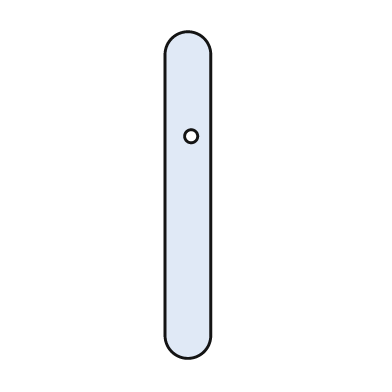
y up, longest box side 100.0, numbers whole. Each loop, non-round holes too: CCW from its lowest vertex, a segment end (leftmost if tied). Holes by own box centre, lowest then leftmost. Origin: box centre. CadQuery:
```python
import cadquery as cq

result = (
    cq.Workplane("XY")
    .moveTo(-7.0, -43.0)
    .threePointArc((0.0, -50.0), (7.0, -43.0))
    .lineTo(7.0, 43.0)
    .threePointArc((0.0, 50.0), (-7.0, 43.0))
    .close()
    .moveTo(1.0, 18.0)
    .circle(2.0)
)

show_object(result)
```